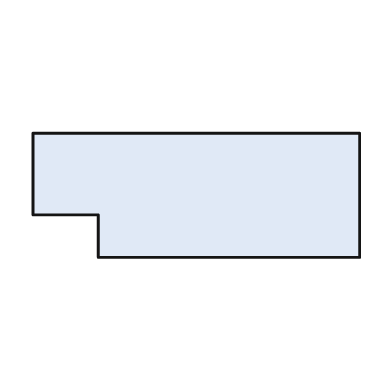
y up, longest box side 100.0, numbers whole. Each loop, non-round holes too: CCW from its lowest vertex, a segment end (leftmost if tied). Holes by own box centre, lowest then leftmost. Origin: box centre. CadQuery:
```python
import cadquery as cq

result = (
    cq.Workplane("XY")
    .moveTo(-30.0, -19.0)
    .lineTo(50.0, -19.0)
    .lineTo(50.0, 19.0)
    .lineTo(-50.0, 19.0)
    .lineTo(-50.0, -6.0)
    .lineTo(-30.0, -6.0)
    .close()
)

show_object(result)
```